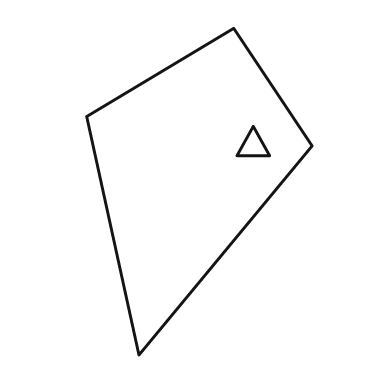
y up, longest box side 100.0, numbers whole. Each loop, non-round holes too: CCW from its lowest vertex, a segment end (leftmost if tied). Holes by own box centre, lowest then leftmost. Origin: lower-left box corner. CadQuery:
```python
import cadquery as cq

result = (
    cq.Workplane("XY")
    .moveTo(16.0, 0.0)
    .lineTo(69.0, 64.0)
    .lineTo(45.0, 100.0)
    .lineTo(0.0, 73.0)
    .close()
    .moveTo(46.0, 61.0)
    .lineTo(56.0, 61.0)
    .lineTo(51.0, 70.0)
    .close()
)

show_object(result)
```